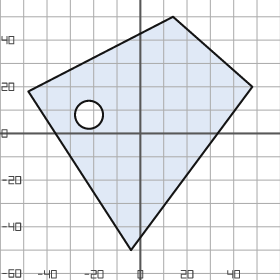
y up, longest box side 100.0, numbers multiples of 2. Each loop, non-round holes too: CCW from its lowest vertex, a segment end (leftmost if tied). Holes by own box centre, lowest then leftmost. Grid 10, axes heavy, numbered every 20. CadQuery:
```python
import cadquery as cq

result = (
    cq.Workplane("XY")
    .moveTo(-4.0, -50.0)
    .lineTo(48.0, 20.0)
    .lineTo(14.0, 50.0)
    .lineTo(-48.0, 18.0)
    .close()
    .moveTo(-22.0, 8.0)
    .circle(6.0)
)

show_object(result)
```